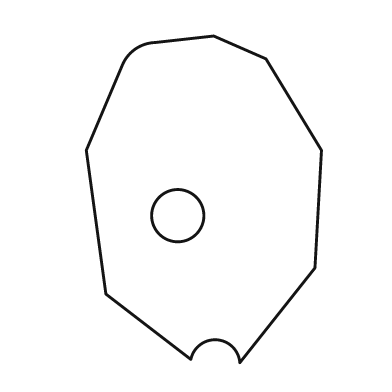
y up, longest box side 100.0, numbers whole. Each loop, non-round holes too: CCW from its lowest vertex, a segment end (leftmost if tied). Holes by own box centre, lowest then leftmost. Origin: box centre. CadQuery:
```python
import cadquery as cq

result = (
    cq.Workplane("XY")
    .moveTo(11.0, -50.0)
    .lineTo(34.0, -21.0)
    .lineTo(36.0, 15.0)
    .lineTo(19.0, 43.0)
    .lineTo(3.0, 50.0)
    .lineTo(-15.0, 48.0)
    .threePointArc((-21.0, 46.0), (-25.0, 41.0))
    .lineTo(-36.0, 15.0)
    .lineTo(-30.0, -29.0)
    .lineTo(-4.0, -49.0)
    .threePointArc((4.0, -43.0), (11.0, -50.0))
    .close()
    .moveTo(-8.0, -5.0)
    .circle(8.0)
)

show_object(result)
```